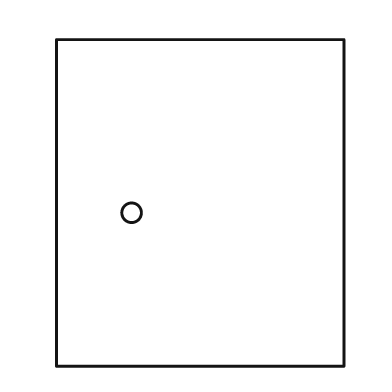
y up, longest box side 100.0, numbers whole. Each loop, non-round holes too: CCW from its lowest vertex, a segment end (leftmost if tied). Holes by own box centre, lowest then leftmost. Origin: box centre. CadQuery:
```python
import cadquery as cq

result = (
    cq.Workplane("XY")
    .moveTo(-44.0, -50.0)
    .lineTo(44.0, -50.0)
    .lineTo(44.0, 50.0)
    .lineTo(-44.0, 50.0)
    .close()
    .moveTo(-21.0, -3.0)
    .circle(3.0)
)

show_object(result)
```